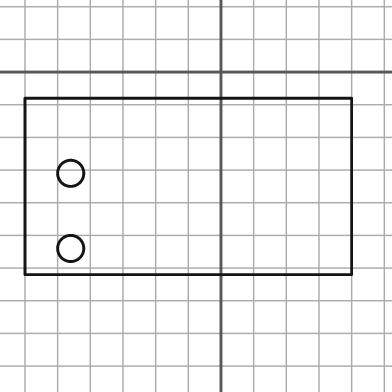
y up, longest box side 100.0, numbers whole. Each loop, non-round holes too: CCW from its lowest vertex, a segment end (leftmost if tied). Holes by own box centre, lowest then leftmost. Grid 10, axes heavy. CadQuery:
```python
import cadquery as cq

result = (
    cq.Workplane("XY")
    .moveTo(-60.0, -62.0)
    .lineTo(40.0, -62.0)
    .lineTo(40.0, -8.0)
    .lineTo(-60.0, -8.0)
    .close()
    .moveTo(-46.0, -54.0)
    .circle(4.0)
    .moveTo(-46.0, -31.0)
    .circle(4.0)
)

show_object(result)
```